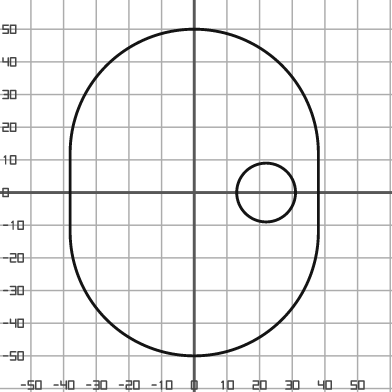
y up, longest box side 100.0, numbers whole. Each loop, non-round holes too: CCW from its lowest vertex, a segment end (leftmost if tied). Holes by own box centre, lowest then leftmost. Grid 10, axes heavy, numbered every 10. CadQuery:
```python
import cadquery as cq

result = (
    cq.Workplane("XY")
    .moveTo(-38.0, -12.0)
    .threePointArc((0.0, -50.0), (38.0, -12.0))
    .lineTo(38.0, 12.0)
    .threePointArc((0.0, 50.0), (-38.0, 12.0))
    .close()
    .moveTo(22.0, 0.0)
    .circle(9.0)
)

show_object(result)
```